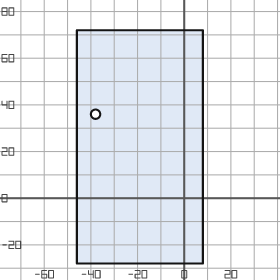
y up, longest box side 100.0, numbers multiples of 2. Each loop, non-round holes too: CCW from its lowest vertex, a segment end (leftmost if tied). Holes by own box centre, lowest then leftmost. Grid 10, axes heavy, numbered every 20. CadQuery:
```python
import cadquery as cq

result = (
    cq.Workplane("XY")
    .moveTo(-46.0, -28.0)
    .lineTo(8.0, -28.0)
    .lineTo(8.0, 72.0)
    .lineTo(-46.0, 72.0)
    .close()
    .moveTo(-38.0, 36.0)
    .circle(2.0)
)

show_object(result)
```